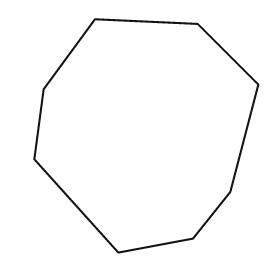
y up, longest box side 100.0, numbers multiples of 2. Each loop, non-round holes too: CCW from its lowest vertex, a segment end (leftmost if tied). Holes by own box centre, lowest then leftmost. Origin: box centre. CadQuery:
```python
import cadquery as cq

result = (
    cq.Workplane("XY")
    .moveTo(-12.0, -50.0)
    .lineTo(20.0, -44.0)
    .lineTo(36.0, -24.0)
    .lineTo(48.0, 22.0)
    .lineTo(22.0, 48.0)
    .lineTo(-22.0, 50.0)
    .lineTo(-44.0, 20.0)
    .lineTo(-48.0, -10.0)
    .close()
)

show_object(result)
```